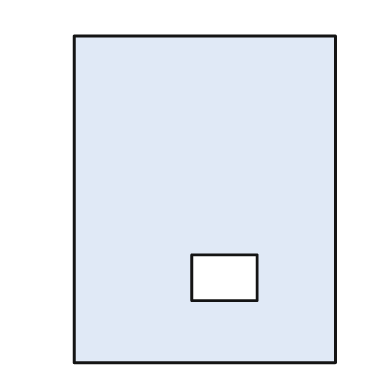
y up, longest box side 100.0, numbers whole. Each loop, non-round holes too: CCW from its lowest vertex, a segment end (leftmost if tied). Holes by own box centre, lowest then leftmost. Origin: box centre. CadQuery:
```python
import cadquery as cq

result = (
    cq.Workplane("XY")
    .moveTo(-40.0, -50.0)
    .lineTo(40.0, -50.0)
    .lineTo(40.0, 50.0)
    .lineTo(-40.0, 50.0)
    .close()
    .moveTo(-4.0, -31.0)
    .lineTo(16.0, -31.0)
    .lineTo(16.0, -17.0)
    .lineTo(-4.0, -17.0)
    .close()
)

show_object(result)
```